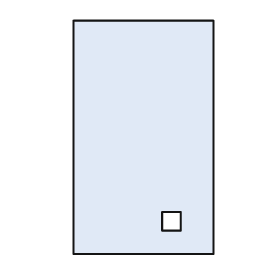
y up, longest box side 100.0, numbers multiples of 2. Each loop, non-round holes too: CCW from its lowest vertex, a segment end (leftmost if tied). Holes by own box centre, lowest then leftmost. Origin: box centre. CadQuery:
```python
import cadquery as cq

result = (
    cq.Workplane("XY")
    .moveTo(-30.0, -50.0)
    .lineTo(30.0, -50.0)
    .lineTo(30.0, 50.0)
    .lineTo(-30.0, 50.0)
    .close()
    .moveTo(8.0, -40.0)
    .lineTo(16.0, -40.0)
    .lineTo(16.0, -32.0)
    .lineTo(8.0, -32.0)
    .close()
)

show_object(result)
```